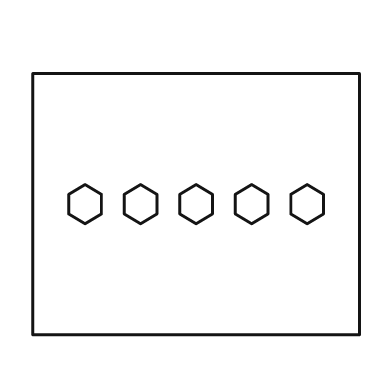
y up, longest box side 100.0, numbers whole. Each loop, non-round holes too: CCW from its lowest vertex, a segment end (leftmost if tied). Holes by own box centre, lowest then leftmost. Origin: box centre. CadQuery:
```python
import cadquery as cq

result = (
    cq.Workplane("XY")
    .moveTo(-50.0, -40.0)
    .lineTo(50.0, -40.0)
    .lineTo(50.0, 40.0)
    .lineTo(-50.0, 40.0)
    .close()
    .moveTo(-34.0, -6.0)
    .lineTo(-29.0, -3.0)
    .lineTo(-29.0, 3.0)
    .lineTo(-34.0, 6.0)
    .lineTo(-39.0, 3.0)
    .lineTo(-39.0, -3.0)
    .close()
    .moveTo(-17.0, -6.0)
    .lineTo(-12.0, -3.0)
    .lineTo(-12.0, 3.0)
    .lineTo(-17.0, 6.0)
    .lineTo(-22.0, 3.0)
    .lineTo(-22.0, -3.0)
    .close()
    .moveTo(0.0, -6.0)
    .lineTo(5.0, -3.0)
    .lineTo(5.0, 3.0)
    .lineTo(0.0, 6.0)
    .lineTo(-5.0, 3.0)
    .lineTo(-5.0, -3.0)
    .close()
    .moveTo(17.0, -6.0)
    .lineTo(22.0, -3.0)
    .lineTo(22.0, 3.0)
    .lineTo(17.0, 6.0)
    .lineTo(12.0, 3.0)
    .lineTo(12.0, -3.0)
    .close()
    .moveTo(34.0, -6.0)
    .lineTo(39.0, -3.0)
    .lineTo(39.0, 3.0)
    .lineTo(34.0, 6.0)
    .lineTo(29.0, 3.0)
    .lineTo(29.0, -3.0)
    .close()
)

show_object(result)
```